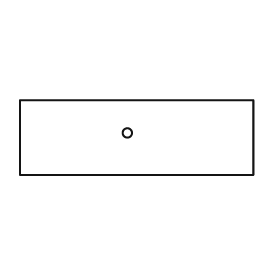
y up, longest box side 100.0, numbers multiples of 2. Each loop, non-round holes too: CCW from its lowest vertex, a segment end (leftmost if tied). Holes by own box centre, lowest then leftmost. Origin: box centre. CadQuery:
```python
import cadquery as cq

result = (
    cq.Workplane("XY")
    .moveTo(-50.0, -16.0)
    .lineTo(50.0, -16.0)
    .lineTo(50.0, 16.0)
    .lineTo(-50.0, 16.0)
    .close()
    .moveTo(-4.0, 2.0)
    .circle(2.0)
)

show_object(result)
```